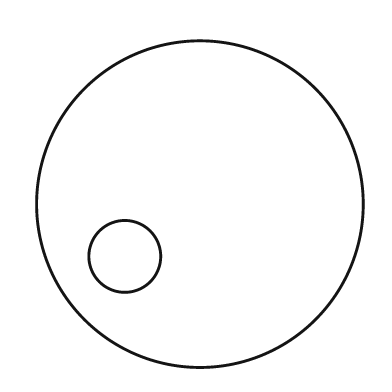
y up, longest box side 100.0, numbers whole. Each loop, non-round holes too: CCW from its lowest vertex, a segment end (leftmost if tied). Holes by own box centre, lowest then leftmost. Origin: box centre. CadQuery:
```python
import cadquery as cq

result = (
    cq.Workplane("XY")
    .moveTo(0.0, 0.0)
    .circle(50.0)
    .moveTo(-23.0, -16.0)
    .circle(11.0)
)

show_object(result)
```